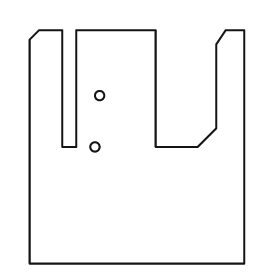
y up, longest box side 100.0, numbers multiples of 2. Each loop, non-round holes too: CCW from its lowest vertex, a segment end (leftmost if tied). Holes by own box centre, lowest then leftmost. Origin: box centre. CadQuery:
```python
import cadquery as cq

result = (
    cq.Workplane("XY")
    .moveTo(-46.0, -50.0)
    .lineTo(46.0, -50.0)
    .lineTo(46.0, 50.0)
    .lineTo(38.0, 50.0)
    .lineTo(34.0, 44.0)
    .lineTo(34.0, 8.0)
    .lineTo(26.0, 0.0)
    .lineTo(8.0, 0.0)
    .lineTo(8.0, 50.0)
    .lineTo(-26.0, 50.0)
    .lineTo(-26.0, 0.0)
    .lineTo(-32.0, 0.0)
    .lineTo(-32.0, 50.0)
    .lineTo(-42.0, 50.0)
    .lineTo(-46.0, 46.0)
    .close()
    .moveTo(-18.0, 0.0)
    .circle(2.0)
    .moveTo(-16.0, 22.0)
    .circle(2.0)
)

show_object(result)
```